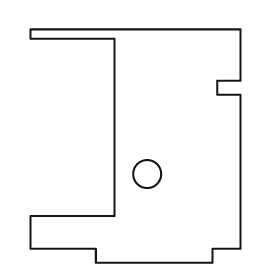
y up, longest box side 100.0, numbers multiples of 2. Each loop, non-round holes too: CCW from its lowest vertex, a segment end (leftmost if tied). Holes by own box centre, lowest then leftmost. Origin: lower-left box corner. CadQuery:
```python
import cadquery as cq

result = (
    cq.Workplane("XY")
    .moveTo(28.0, 0.0)
    .lineTo(78.0, 0.0)
    .lineTo(78.0, 6.0)
    .lineTo(90.0, 6.0)
    .lineTo(90.0, 72.0)
    .lineTo(80.0, 72.0)
    .lineTo(80.0, 78.0)
    .lineTo(90.0, 78.0)
    .lineTo(90.0, 100.0)
    .lineTo(0.0, 100.0)
    .lineTo(0.0, 96.0)
    .lineTo(36.0, 96.0)
    .lineTo(36.0, 20.0)
    .lineTo(0.0, 20.0)
    .lineTo(0.0, 6.0)
    .lineTo(28.0, 6.0)
    .close()
    .moveTo(50.0, 38.0)
    .circle(6.0)
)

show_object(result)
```